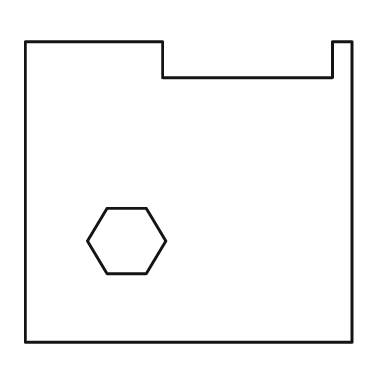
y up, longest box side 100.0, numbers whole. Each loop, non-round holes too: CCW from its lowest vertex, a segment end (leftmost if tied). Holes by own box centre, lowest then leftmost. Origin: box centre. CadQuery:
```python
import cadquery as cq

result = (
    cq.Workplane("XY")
    .moveTo(-50.0, -46.0)
    .lineTo(50.0, -46.0)
    .lineTo(50.0, 46.0)
    .lineTo(44.0, 46.0)
    .lineTo(44.0, 35.0)
    .lineTo(-8.0, 35.0)
    .lineTo(-8.0, 46.0)
    .lineTo(-50.0, 46.0)
    .close()
    .moveTo(-25.0, -25.0)
    .lineTo(-13.0, -25.0)
    .lineTo(-7.0, -15.0)
    .lineTo(-13.0, -5.0)
    .lineTo(-25.0, -5.0)
    .lineTo(-31.0, -15.0)
    .close()
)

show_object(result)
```